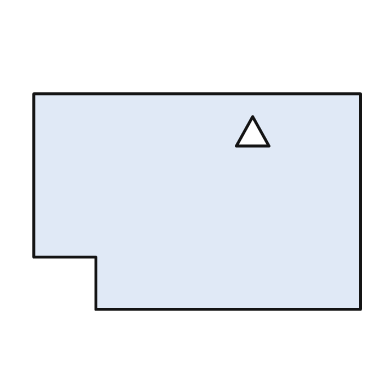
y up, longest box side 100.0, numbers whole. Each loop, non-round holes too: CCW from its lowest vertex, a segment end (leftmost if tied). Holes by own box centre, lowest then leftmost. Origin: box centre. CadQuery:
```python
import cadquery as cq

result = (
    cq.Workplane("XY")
    .moveTo(-31.0, -33.0)
    .lineTo(50.0, -33.0)
    .lineTo(50.0, 33.0)
    .lineTo(-50.0, 33.0)
    .lineTo(-50.0, -17.0)
    .lineTo(-31.0, -17.0)
    .close()
    .moveTo(12.0, 17.0)
    .lineTo(22.0, 17.0)
    .lineTo(17.0, 26.0)
    .close()
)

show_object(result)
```